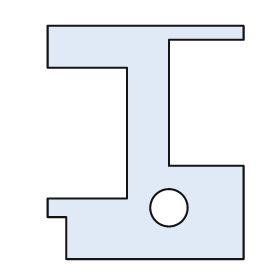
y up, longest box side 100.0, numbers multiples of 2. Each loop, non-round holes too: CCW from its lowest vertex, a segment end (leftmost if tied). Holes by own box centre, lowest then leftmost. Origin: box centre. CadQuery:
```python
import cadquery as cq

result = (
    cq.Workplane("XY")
    .moveTo(-34.0, -50.0)
    .lineTo(42.0, -50.0)
    .lineTo(42.0, -10.0)
    .lineTo(10.0, -10.0)
    .lineTo(10.0, 44.0)
    .lineTo(42.0, 44.0)
    .lineTo(42.0, 50.0)
    .lineTo(-42.0, 50.0)
    .lineTo(-42.0, 32.0)
    .lineTo(-8.0, 32.0)
    .lineTo(-8.0, -24.0)
    .lineTo(-42.0, -24.0)
    .lineTo(-42.0, -32.0)
    .lineTo(-34.0, -32.0)
    .close()
    .moveTo(10.0, -28.0)
    .circle(8.0)
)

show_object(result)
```